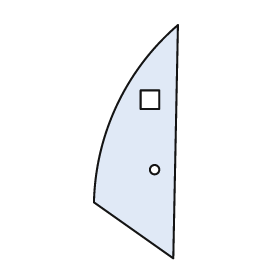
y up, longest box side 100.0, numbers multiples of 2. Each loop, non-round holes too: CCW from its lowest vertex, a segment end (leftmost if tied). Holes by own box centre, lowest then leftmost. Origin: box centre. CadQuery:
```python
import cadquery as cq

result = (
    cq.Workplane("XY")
    .moveTo(16.0, -50.0)
    .lineTo(18.0, 50.0)
    .threePointArc((-8.0, 16.0), (-18.0, -26.0))
    .close()
    .moveTo(8.0, -12.0)
    .circle(2.0)
    .moveTo(2.0, 14.0)
    .lineTo(10.0, 14.0)
    .lineTo(10.0, 22.0)
    .lineTo(2.0, 22.0)
    .close()
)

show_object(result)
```